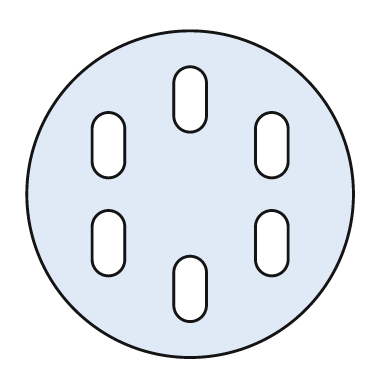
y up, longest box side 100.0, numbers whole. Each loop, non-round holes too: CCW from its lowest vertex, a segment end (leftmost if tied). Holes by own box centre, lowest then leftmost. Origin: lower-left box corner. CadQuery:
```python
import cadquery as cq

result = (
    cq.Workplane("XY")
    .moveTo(50.0, 50.0)
    .circle(50.0)
    .moveTo(45.0, 16.0)
    .threePointArc((50.0, 11.0), (55.0, 16.0))
    .lineTo(55.0, 26.0)
    .threePointArc((50.0, 31.0), (45.0, 26.0))
    .close()
    .moveTo(20.0, 30.0)
    .threePointArc((25.0, 25.0), (30.0, 30.0))
    .lineTo(30.0, 40.0)
    .threePointArc((25.0, 45.0), (20.0, 40.0))
    .close()
    .moveTo(70.0, 30.0)
    .threePointArc((75.0, 25.0), (80.0, 30.0))
    .lineTo(80.0, 40.0)
    .threePointArc((75.0, 45.0), (70.0, 40.0))
    .close()
    .moveTo(20.0, 60.0)
    .threePointArc((25.0, 55.0), (30.0, 60.0))
    .lineTo(30.0, 70.0)
    .threePointArc((25.0, 75.0), (20.0, 70.0))
    .close()
    .moveTo(70.0, 60.0)
    .threePointArc((75.0, 55.0), (80.0, 60.0))
    .lineTo(80.0, 70.0)
    .threePointArc((75.0, 75.0), (70.0, 70.0))
    .close()
    .moveTo(45.0, 74.0)
    .threePointArc((50.0, 69.0), (55.0, 74.0))
    .lineTo(55.0, 84.0)
    .threePointArc((50.0, 89.0), (45.0, 84.0))
    .close()
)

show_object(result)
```